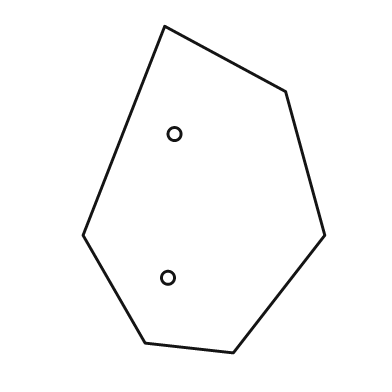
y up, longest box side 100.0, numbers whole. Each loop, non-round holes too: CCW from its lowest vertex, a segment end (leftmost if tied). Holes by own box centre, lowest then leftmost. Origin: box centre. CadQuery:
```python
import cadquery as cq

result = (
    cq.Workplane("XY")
    .moveTo(9.0, -50.0)
    .lineTo(37.0, -14.0)
    .lineTo(25.0, 30.0)
    .lineTo(-12.0, 50.0)
    .lineTo(-37.0, -14.0)
    .lineTo(-18.0, -47.0)
    .close()
    .moveTo(-11.0, -27.0)
    .circle(2.0)
    .moveTo(-9.0, 17.0)
    .circle(2.0)
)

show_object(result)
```